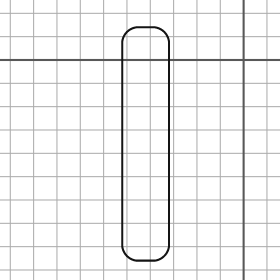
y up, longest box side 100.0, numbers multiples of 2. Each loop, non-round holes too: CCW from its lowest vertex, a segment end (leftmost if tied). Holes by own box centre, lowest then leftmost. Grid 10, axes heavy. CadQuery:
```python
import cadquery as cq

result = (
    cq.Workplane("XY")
    .moveTo(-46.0, -86.0)
    .lineTo(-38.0, -86.0)
    .threePointArc((-34.0, -84.0), (-32.0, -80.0))
    .lineTo(-32.0, 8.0)
    .threePointArc((-34.0, 12.0), (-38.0, 14.0))
    .lineTo(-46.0, 14.0)
    .threePointArc((-50.0, 12.0), (-52.0, 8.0))
    .lineTo(-52.0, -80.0)
    .threePointArc((-50.0, -84.0), (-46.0, -86.0))
    .close()
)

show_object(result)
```